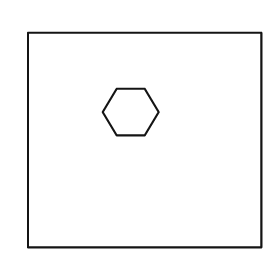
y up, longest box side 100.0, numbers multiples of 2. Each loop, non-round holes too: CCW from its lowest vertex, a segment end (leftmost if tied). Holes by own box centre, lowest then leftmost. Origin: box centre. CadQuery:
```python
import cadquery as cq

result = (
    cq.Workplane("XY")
    .moveTo(-50.0, -46.0)
    .lineTo(50.0, -46.0)
    .lineTo(50.0, 46.0)
    .lineTo(-50.0, 46.0)
    .close()
    .moveTo(-12.0, 2.0)
    .lineTo(0.0, 2.0)
    .lineTo(6.0, 12.0)
    .lineTo(0.0, 22.0)
    .lineTo(-12.0, 22.0)
    .lineTo(-18.0, 12.0)
    .close()
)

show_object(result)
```